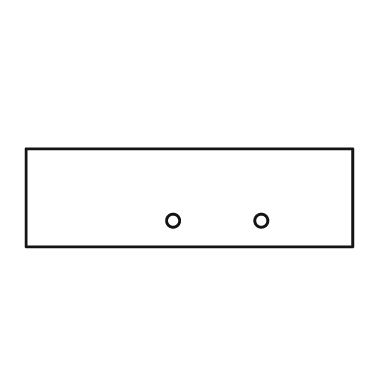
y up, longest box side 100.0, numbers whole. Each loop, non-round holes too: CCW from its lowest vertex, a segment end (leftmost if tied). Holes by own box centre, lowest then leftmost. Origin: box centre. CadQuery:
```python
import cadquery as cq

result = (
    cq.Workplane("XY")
    .moveTo(-50.0, -15.0)
    .lineTo(50.0, -15.0)
    .lineTo(50.0, 15.0)
    .lineTo(-50.0, 15.0)
    .close()
    .moveTo(-5.0, -7.0)
    .circle(2.0)
    .moveTo(22.0, -7.0)
    .circle(2.0)
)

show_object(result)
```